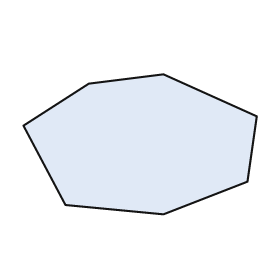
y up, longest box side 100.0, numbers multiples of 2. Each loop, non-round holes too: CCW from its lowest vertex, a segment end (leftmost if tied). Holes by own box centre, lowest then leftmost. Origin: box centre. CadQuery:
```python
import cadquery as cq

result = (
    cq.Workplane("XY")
    .moveTo(10.0, -30.0)
    .lineTo(46.0, -16.0)
    .lineTo(50.0, 12.0)
    .lineTo(10.0, 30.0)
    .lineTo(-22.0, 26.0)
    .lineTo(-50.0, 8.0)
    .lineTo(-32.0, -26.0)
    .close()
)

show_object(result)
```